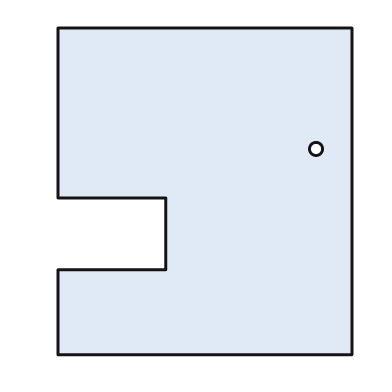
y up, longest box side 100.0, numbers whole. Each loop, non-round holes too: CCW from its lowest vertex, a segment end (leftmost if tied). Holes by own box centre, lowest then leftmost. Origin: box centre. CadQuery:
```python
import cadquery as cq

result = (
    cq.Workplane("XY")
    .moveTo(-45.0, -50.0)
    .lineTo(45.0, -50.0)
    .lineTo(45.0, 50.0)
    .lineTo(-45.0, 50.0)
    .lineTo(-45.0, -2.0)
    .lineTo(-12.0, -2.0)
    .lineTo(-12.0, -24.0)
    .lineTo(-45.0, -24.0)
    .close()
    .moveTo(34.0, 13.0)
    .circle(2.0)
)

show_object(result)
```